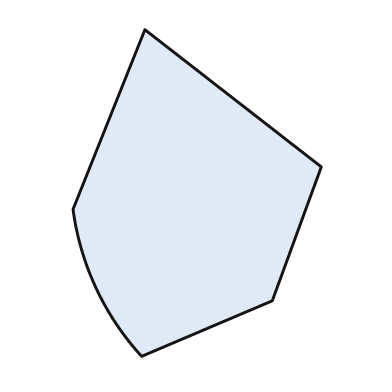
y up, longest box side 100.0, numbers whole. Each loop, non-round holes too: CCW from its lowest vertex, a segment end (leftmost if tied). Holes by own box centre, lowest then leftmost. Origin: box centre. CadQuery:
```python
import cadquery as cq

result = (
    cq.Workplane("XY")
    .moveTo(-17.0, -50.0)
    .lineTo(23.0, -33.0)
    .lineTo(38.0, 8.0)
    .lineTo(-16.0, 50.0)
    .lineTo(-38.0, -5.0)
    .threePointArc((-31.0, -29.0), (-17.0, -50.0))
    .close()
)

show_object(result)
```